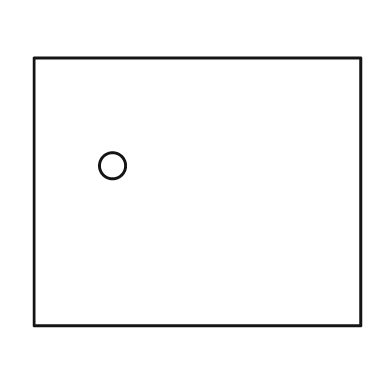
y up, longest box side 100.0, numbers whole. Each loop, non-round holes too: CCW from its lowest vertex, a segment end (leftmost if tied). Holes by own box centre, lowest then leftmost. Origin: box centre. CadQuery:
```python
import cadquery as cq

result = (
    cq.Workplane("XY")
    .moveTo(-50.0, -41.0)
    .lineTo(50.0, -41.0)
    .lineTo(50.0, 41.0)
    .lineTo(-50.0, 41.0)
    .close()
    .moveTo(-26.0, 8.0)
    .circle(4.0)
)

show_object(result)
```